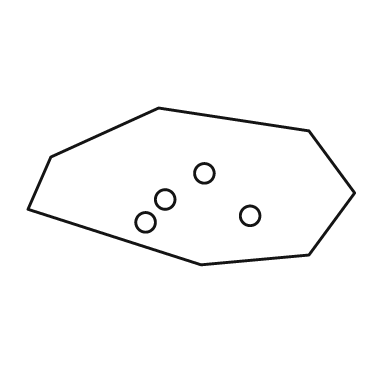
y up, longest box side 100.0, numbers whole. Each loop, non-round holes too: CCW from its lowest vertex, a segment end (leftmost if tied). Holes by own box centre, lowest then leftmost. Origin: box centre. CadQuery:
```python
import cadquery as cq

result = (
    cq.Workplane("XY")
    .moveTo(3.0, -24.0)
    .lineTo(36.0, -21.0)
    .lineTo(50.0, -2.0)
    .lineTo(36.0, 17.0)
    .lineTo(-10.0, 24.0)
    .lineTo(-43.0, 9.0)
    .lineTo(-50.0, -7.0)
    .close()
    .moveTo(-14.0, -11.0)
    .circle(3.0)
    .moveTo(18.0, -9.0)
    .circle(3.0)
    .moveTo(-8.0, -4.0)
    .circle(3.0)
    .moveTo(4.0, 4.0)
    .circle(3.0)
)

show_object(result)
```